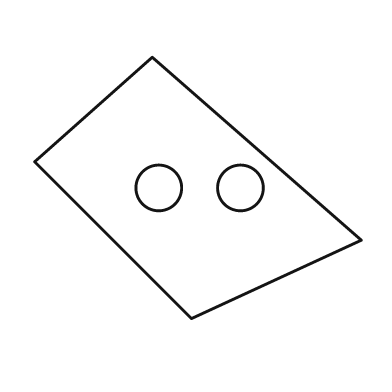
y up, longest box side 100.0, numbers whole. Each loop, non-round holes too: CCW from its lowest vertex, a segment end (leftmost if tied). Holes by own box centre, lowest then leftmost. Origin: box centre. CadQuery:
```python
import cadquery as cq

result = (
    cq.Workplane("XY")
    .moveTo(-2.0, -40.0)
    .lineTo(50.0, -16.0)
    .lineTo(-14.0, 40.0)
    .lineTo(-50.0, 8.0)
    .close()
    .moveTo(-12.0, 0.0)
    .circle(7.0)
    .moveTo(13.0, 0.0)
    .circle(7.0)
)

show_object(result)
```